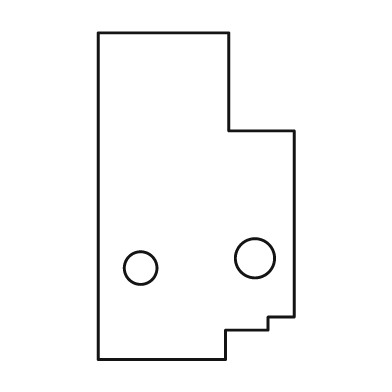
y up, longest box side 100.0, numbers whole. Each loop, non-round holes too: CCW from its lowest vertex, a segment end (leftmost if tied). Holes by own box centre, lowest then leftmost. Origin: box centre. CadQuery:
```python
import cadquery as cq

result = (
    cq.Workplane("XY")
    .moveTo(-30.0, -50.0)
    .lineTo(9.0, -50.0)
    .lineTo(9.0, -41.0)
    .lineTo(22.0, -41.0)
    .lineTo(22.0, -37.0)
    .lineTo(30.0, -37.0)
    .lineTo(30.0, 20.0)
    .lineTo(10.0, 20.0)
    .lineTo(10.0, 50.0)
    .lineTo(-30.0, 50.0)
    .close()
    .moveTo(-17.0, -22.0)
    .circle(5.0)
    .moveTo(18.0, -19.0)
    .circle(6.0)
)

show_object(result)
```